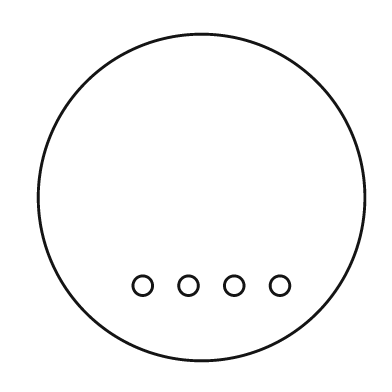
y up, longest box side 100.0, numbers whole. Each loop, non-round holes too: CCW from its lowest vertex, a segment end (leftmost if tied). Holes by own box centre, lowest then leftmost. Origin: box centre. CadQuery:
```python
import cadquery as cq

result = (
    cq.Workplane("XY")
    .moveTo(0.0, 0.0)
    .circle(50.0)
    .moveTo(-18.0, -27.0)
    .circle(3.0)
    .moveTo(-4.0, -27.0)
    .circle(3.0)
    .moveTo(10.0, -27.0)
    .circle(3.0)
    .moveTo(24.0, -27.0)
    .circle(3.0)
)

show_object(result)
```